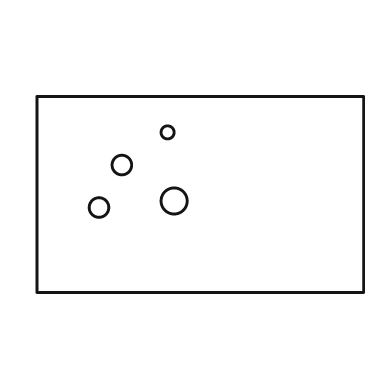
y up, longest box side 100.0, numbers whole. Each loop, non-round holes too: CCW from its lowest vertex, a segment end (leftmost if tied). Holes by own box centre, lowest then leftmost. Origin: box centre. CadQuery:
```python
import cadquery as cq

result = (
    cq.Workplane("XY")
    .moveTo(-50.0, -30.0)
    .lineTo(50.0, -30.0)
    .lineTo(50.0, 30.0)
    .lineTo(-50.0, 30.0)
    .close()
    .moveTo(-31.0, -4.0)
    .circle(3.0)
    .moveTo(-8.0, -2.0)
    .circle(4.0)
    .moveTo(-24.0, 9.0)
    .circle(3.0)
    .moveTo(-10.0, 19.0)
    .circle(2.0)
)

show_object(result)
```